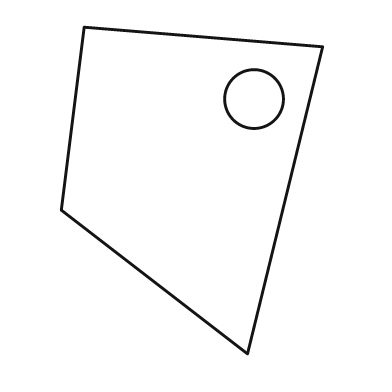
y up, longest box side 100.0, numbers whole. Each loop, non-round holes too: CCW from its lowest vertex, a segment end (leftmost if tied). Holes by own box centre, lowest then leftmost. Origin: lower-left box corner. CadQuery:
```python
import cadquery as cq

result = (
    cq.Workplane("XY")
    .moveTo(57.0, 0.0)
    .lineTo(80.0, 94.0)
    .lineTo(7.0, 100.0)
    .lineTo(0.0, 44.0)
    .close()
    .moveTo(59.0, 78.0)
    .circle(9.0)
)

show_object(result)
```